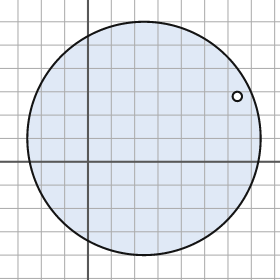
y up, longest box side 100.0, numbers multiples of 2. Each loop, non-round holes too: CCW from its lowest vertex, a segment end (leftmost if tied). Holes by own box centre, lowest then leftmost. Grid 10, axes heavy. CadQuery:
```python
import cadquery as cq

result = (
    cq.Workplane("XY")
    .moveTo(24.0, 10.0)
    .circle(50.0)
    .moveTo(64.0, 28.0)
    .circle(2.0)
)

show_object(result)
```